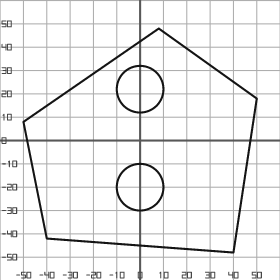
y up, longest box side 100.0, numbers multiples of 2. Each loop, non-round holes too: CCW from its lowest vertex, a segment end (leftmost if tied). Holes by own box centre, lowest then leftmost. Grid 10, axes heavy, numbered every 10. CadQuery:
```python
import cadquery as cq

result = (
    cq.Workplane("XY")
    .moveTo(40.0, -48.0)
    .lineTo(50.0, 18.0)
    .lineTo(8.0, 48.0)
    .lineTo(-50.0, 8.0)
    .lineTo(-40.0, -42.0)
    .close()
    .moveTo(0.0, -20.0)
    .circle(10.0)
    .moveTo(0.0, 22.0)
    .circle(10.0)
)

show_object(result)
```